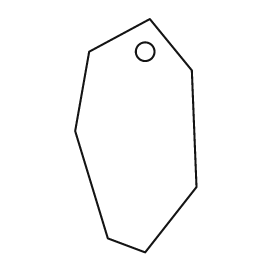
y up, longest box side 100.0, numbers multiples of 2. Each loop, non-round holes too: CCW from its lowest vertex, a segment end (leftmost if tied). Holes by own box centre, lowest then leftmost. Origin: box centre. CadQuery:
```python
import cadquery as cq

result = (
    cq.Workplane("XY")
    .moveTo(4.0, -50.0)
    .lineTo(26.0, -22.0)
    .lineTo(24.0, 28.0)
    .lineTo(6.0, 50.0)
    .lineTo(-20.0, 36.0)
    .lineTo(-26.0, 2.0)
    .lineTo(-12.0, -44.0)
    .close()
    .moveTo(4.0, 36.0)
    .circle(4.0)
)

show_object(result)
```